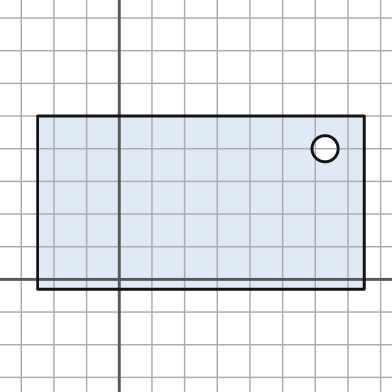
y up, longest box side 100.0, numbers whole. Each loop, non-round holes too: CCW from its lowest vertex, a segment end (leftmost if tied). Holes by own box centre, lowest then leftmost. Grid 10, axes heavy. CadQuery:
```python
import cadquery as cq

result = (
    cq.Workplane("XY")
    .moveTo(-25.0, -3.0)
    .lineTo(75.0, -3.0)
    .lineTo(75.0, 50.0)
    .lineTo(-25.0, 50.0)
    .close()
    .moveTo(63.0, 40.0)
    .circle(4.0)
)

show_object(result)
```